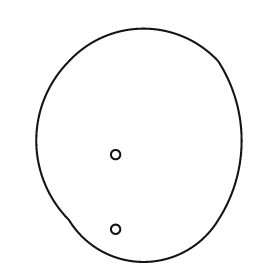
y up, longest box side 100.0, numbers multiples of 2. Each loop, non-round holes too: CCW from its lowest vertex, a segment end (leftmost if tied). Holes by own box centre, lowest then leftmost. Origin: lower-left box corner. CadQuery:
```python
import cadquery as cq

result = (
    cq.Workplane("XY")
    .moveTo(14.0, 18.0)
    .threePointArc((46.0, 0.0), (78.0, 18.0))
    .threePointArc((88.0, 52.0), (78.0, 86.0))
    .threePointArc((46.0, 100.0), (14.0, 86.0))
    .threePointArc((0.0, 52.0), (14.0, 18.0))
    .close()
    .moveTo(34.0, 14.0)
    .circle(2.0)
    .moveTo(34.0, 46.0)
    .circle(2.0)
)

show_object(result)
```